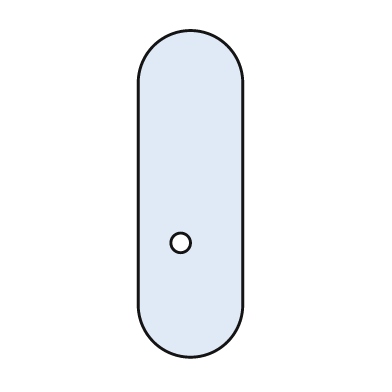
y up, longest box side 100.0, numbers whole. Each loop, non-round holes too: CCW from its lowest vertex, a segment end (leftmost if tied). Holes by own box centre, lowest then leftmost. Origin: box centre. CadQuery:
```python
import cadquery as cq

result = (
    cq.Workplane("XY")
    .moveTo(-16.0, -34.0)
    .threePointArc((0.0, -50.0), (16.0, -34.0))
    .lineTo(16.0, 34.0)
    .threePointArc((0.0, 50.0), (-16.0, 34.0))
    .close()
    .moveTo(-3.0, -15.0)
    .circle(3.0)
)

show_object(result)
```